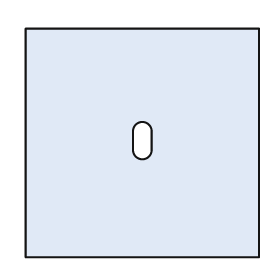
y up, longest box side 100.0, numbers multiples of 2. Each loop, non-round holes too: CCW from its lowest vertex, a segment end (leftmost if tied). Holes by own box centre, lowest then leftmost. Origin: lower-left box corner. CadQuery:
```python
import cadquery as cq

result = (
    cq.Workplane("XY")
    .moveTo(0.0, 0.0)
    .lineTo(100.0, 0.0)
    .lineTo(100.0, 98.0)
    .lineTo(0.0, 98.0)
    .close()
    .moveTo(46.0, 46.0)
    .threePointArc((50.0, 42.0), (54.0, 46.0))
    .lineTo(54.0, 54.0)
    .threePointArc((50.0, 58.0), (46.0, 54.0))
    .close()
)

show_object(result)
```